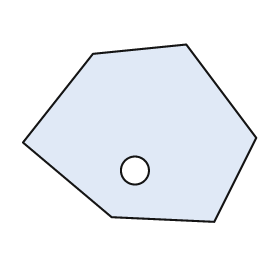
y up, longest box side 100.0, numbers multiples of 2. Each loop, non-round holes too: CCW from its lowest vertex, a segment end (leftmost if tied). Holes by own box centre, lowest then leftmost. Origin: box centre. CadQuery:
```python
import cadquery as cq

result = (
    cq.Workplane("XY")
    .moveTo(32.0, -38.0)
    .lineTo(50.0, -2.0)
    .lineTo(20.0, 38.0)
    .lineTo(-20.0, 34.0)
    .lineTo(-50.0, -4.0)
    .lineTo(-12.0, -36.0)
    .close()
    .moveTo(-2.0, -16.0)
    .circle(6.0)
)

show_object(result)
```